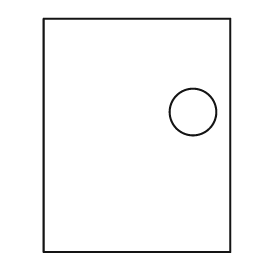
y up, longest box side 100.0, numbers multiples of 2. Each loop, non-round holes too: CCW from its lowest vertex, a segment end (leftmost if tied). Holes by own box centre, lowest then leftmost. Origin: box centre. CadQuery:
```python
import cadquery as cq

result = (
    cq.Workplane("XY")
    .moveTo(-40.0, -50.0)
    .lineTo(40.0, -50.0)
    .lineTo(40.0, 50.0)
    .lineTo(-40.0, 50.0)
    .close()
    .moveTo(24.0, 10.0)
    .circle(10.0)
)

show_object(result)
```